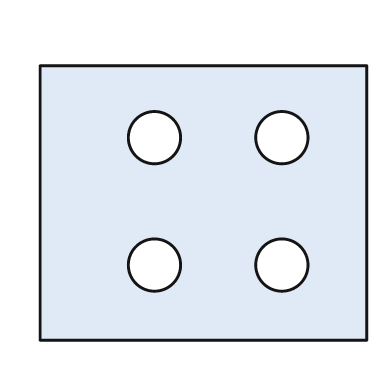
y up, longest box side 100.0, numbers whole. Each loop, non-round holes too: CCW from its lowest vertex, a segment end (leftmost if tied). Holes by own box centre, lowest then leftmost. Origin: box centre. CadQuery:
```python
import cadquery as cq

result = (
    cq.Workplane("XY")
    .moveTo(-50.0, -42.0)
    .lineTo(50.0, -42.0)
    .lineTo(50.0, 42.0)
    .lineTo(-50.0, 42.0)
    .close()
    .moveTo(-15.0, -19.0)
    .circle(8.0)
    .moveTo(24.0, -19.0)
    .circle(8.0)
    .moveTo(-15.0, 20.0)
    .circle(8.0)
    .moveTo(24.0, 20.0)
    .circle(8.0)
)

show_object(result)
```